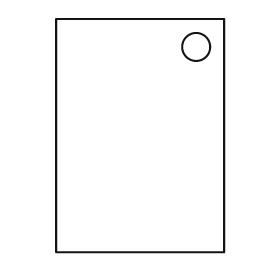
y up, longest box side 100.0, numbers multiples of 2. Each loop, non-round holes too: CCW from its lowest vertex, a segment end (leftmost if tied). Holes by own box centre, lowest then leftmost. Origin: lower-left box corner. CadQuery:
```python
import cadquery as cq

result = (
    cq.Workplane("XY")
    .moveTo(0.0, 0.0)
    .lineTo(72.0, 0.0)
    .lineTo(72.0, 100.0)
    .lineTo(0.0, 100.0)
    .close()
    .moveTo(60.0, 88.0)
    .circle(6.0)
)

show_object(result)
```